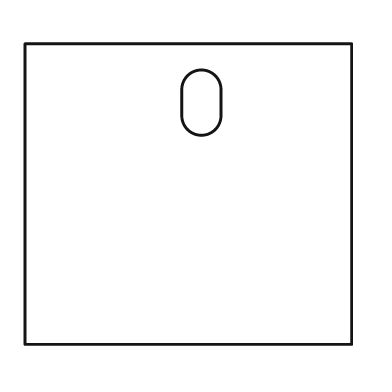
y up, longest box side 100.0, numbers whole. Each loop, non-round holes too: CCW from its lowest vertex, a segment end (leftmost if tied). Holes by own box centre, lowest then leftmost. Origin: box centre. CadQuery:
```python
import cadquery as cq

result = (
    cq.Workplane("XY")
    .moveTo(-50.0, -46.0)
    .lineTo(50.0, -46.0)
    .lineTo(50.0, 46.0)
    .lineTo(-50.0, 46.0)
    .close()
    .moveTo(-2.0, 24.0)
    .threePointArc((4.0, 18.0), (10.0, 24.0))
    .lineTo(10.0, 32.0)
    .threePointArc((4.0, 38.0), (-2.0, 32.0))
    .close()
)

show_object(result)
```